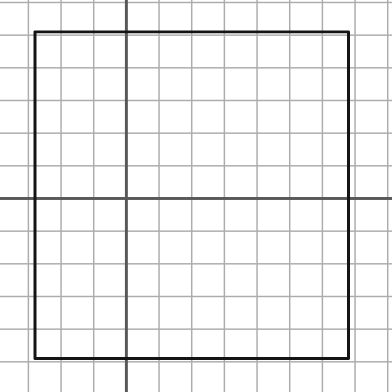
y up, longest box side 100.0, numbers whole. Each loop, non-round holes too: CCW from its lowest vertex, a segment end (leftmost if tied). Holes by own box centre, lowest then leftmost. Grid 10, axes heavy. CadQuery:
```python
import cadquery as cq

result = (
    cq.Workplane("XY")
    .moveTo(-28.0, -49.0)
    .lineTo(68.0, -49.0)
    .lineTo(68.0, 51.0)
    .lineTo(-28.0, 51.0)
    .close()
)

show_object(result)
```